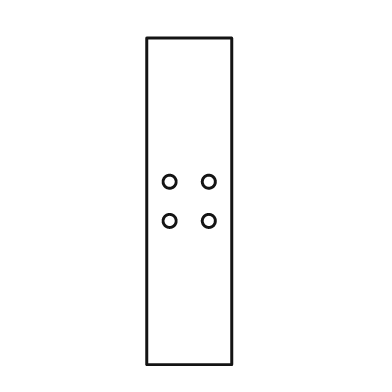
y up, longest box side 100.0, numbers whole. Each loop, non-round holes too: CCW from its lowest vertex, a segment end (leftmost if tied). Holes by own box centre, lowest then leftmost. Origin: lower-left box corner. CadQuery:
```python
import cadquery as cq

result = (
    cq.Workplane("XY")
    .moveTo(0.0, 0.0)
    .lineTo(26.0, 0.0)
    .lineTo(26.0, 100.0)
    .lineTo(0.0, 100.0)
    .close()
    .moveTo(7.0, 44.0)
    .circle(2.0)
    .moveTo(19.0, 44.0)
    .circle(2.0)
    .moveTo(7.0, 56.0)
    .circle(2.0)
    .moveTo(19.0, 56.0)
    .circle(2.0)
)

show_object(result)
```